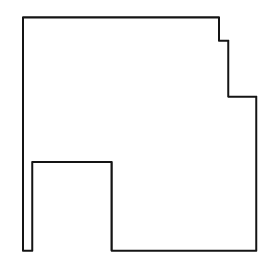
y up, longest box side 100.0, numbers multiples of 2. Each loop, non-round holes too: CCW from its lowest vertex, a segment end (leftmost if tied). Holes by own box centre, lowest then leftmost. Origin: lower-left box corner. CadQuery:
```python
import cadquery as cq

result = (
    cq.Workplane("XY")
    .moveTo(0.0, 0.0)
    .lineTo(4.0, 0.0)
    .lineTo(4.0, 38.0)
    .lineTo(38.0, 38.0)
    .lineTo(38.0, 0.0)
    .lineTo(100.0, 0.0)
    .lineTo(100.0, 66.0)
    .lineTo(88.0, 66.0)
    .lineTo(88.0, 90.0)
    .lineTo(84.0, 90.0)
    .lineTo(84.0, 100.0)
    .lineTo(0.0, 100.0)
    .close()
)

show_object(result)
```